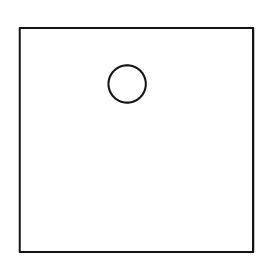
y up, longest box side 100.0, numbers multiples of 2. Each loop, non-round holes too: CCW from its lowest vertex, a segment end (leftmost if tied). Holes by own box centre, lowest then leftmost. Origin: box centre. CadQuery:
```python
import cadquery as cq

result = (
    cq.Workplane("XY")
    .moveTo(-50.0, -48.0)
    .lineTo(50.0, -48.0)
    .lineTo(50.0, 48.0)
    .lineTo(-50.0, 48.0)
    .close()
    .moveTo(-4.0, 24.0)
    .circle(8.0)
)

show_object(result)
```